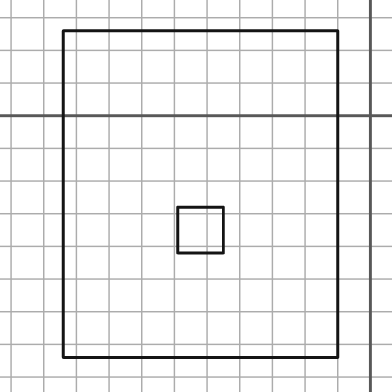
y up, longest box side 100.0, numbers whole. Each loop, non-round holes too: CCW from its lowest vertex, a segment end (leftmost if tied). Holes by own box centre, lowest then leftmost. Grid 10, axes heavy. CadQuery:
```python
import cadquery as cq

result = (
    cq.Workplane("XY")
    .moveTo(-94.0, -74.0)
    .lineTo(-10.0, -74.0)
    .lineTo(-10.0, 26.0)
    .lineTo(-94.0, 26.0)
    .close()
    .moveTo(-59.0, -42.0)
    .lineTo(-45.0, -42.0)
    .lineTo(-45.0, -28.0)
    .lineTo(-59.0, -28.0)
    .close()
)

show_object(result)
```